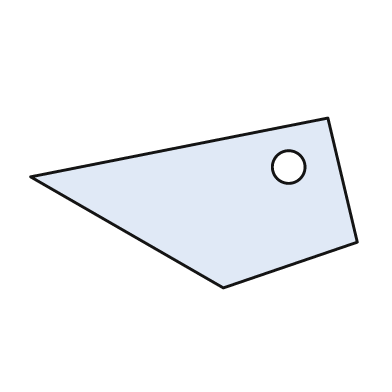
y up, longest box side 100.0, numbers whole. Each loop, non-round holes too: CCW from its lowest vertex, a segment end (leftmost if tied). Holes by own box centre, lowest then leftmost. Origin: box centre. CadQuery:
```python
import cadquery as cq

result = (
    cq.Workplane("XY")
    .moveTo(9.0, -26.0)
    .lineTo(50.0, -12.0)
    .lineTo(41.0, 26.0)
    .lineTo(-50.0, 8.0)
    .close()
    .moveTo(29.0, 11.0)
    .circle(5.0)
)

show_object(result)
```